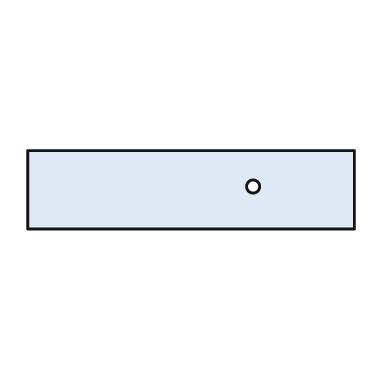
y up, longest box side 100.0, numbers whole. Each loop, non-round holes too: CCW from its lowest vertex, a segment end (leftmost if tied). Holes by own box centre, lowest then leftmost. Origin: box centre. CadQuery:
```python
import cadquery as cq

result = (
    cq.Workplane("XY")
    .moveTo(-50.0, -12.0)
    .lineTo(50.0, -12.0)
    .lineTo(50.0, 12.0)
    .lineTo(-50.0, 12.0)
    .close()
    .moveTo(19.0, 1.0)
    .circle(2.0)
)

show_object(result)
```